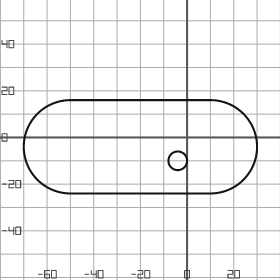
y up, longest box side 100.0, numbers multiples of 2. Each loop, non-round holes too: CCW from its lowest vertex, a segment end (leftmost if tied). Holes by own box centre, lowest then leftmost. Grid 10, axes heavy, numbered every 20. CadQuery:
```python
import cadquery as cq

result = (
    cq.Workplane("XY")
    .moveTo(-50.0, -24.0)
    .lineTo(10.0, -24.0)
    .threePointArc((30.0, -4.0), (10.0, 16.0))
    .lineTo(-50.0, 16.0)
    .threePointArc((-70.0, -4.0), (-50.0, -24.0))
    .close()
    .moveTo(-4.0, -10.0)
    .circle(4.0)
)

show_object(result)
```